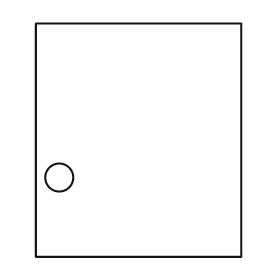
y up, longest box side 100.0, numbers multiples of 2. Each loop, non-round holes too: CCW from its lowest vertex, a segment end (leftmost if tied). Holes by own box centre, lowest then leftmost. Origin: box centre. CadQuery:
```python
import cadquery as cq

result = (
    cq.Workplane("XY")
    .moveTo(-44.0, -50.0)
    .lineTo(44.0, -50.0)
    .lineTo(44.0, 50.0)
    .lineTo(-44.0, 50.0)
    .close()
    .moveTo(-34.0, -16.0)
    .circle(6.0)
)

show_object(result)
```